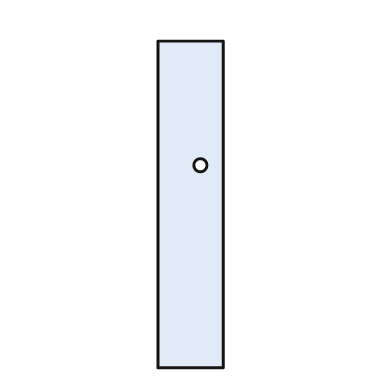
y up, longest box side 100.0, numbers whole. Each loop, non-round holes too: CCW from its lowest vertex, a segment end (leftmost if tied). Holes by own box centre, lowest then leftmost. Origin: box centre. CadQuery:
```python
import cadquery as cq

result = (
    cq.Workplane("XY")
    .moveTo(-10.0, -50.0)
    .lineTo(10.0, -50.0)
    .lineTo(10.0, 50.0)
    .lineTo(-10.0, 50.0)
    .close()
    .moveTo(3.0, 12.0)
    .circle(2.0)
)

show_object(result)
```